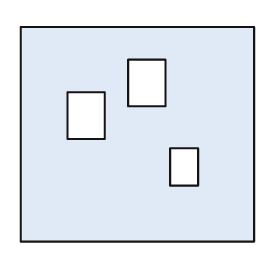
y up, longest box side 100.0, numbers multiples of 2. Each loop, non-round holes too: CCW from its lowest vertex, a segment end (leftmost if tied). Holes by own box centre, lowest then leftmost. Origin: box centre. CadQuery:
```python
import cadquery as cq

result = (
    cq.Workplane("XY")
    .moveTo(-50.0, -46.0)
    .lineTo(50.0, -46.0)
    .lineTo(50.0, 46.0)
    .lineTo(-50.0, 46.0)
    .close()
    .moveTo(14.0, -22.0)
    .lineTo(26.0, -22.0)
    .lineTo(26.0, -6.0)
    .lineTo(14.0, -6.0)
    .close()
    .moveTo(-30.0, -2.0)
    .lineTo(-14.0, -2.0)
    .lineTo(-14.0, 18.0)
    .lineTo(-30.0, 18.0)
    .close()
    .moveTo(-4.0, 12.0)
    .lineTo(12.0, 12.0)
    .lineTo(12.0, 32.0)
    .lineTo(-4.0, 32.0)
    .close()
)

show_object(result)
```